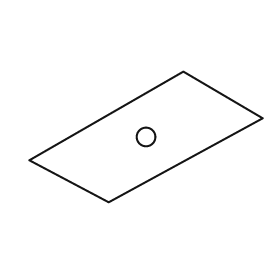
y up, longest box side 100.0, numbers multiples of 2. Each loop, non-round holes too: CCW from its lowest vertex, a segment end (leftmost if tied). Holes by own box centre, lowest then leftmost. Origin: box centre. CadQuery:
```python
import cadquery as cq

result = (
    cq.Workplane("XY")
    .moveTo(-16.0, -28.0)
    .lineTo(50.0, 8.0)
    .lineTo(16.0, 28.0)
    .lineTo(-50.0, -10.0)
    .close()
    .moveTo(0.0, 0.0)
    .circle(4.0)
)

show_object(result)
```